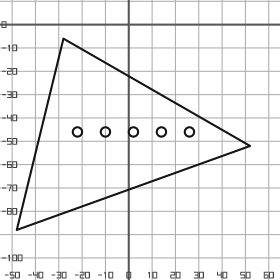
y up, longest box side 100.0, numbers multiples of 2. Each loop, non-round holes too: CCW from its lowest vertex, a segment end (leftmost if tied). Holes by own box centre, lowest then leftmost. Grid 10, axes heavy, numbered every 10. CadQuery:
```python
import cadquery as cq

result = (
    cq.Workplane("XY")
    .moveTo(-48.0, -88.0)
    .lineTo(52.0, -52.0)
    .lineTo(-28.0, -6.0)
    .close()
    .moveTo(-22.0, -46.0)
    .circle(2.0)
    .moveTo(-10.0, -46.0)
    .circle(2.0)
    .moveTo(2.0, -46.0)
    .circle(2.0)
    .moveTo(14.0, -46.0)
    .circle(2.0)
    .moveTo(26.0, -46.0)
    .circle(2.0)
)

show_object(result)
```